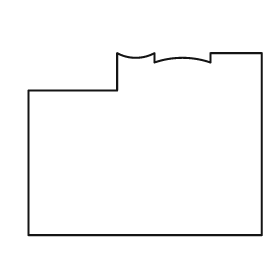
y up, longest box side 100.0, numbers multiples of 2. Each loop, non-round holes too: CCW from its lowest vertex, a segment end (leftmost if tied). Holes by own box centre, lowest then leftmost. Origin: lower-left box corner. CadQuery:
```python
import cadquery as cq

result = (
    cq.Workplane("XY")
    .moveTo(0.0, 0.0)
    .lineTo(100.0, 0.0)
    .lineTo(100.0, 78.0)
    .lineTo(78.0, 78.0)
    .lineTo(78.0, 74.0)
    .threePointArc((66.0, 76.0), (54.0, 74.0))
    .lineTo(54.0, 78.0)
    .threePointArc((46.0, 76.0), (38.0, 78.0))
    .lineTo(38.0, 62.0)
    .lineTo(0.0, 62.0)
    .close()
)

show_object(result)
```